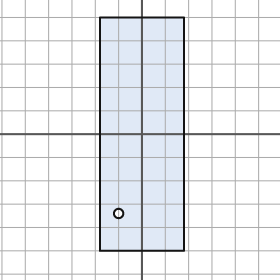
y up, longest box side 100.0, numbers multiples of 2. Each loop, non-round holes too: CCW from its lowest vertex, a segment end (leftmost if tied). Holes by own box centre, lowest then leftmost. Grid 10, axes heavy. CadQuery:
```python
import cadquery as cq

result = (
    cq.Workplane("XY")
    .moveTo(-18.0, -50.0)
    .lineTo(18.0, -50.0)
    .lineTo(18.0, 50.0)
    .lineTo(-18.0, 50.0)
    .close()
    .moveTo(-10.0, -34.0)
    .circle(2.0)
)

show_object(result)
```